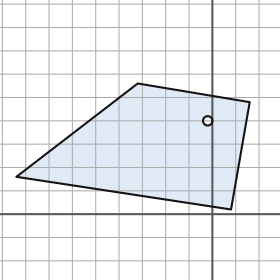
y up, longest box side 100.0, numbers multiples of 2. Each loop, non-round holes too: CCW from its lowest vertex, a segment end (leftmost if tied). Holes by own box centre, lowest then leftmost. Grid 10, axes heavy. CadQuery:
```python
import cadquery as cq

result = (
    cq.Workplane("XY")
    .moveTo(8.0, 2.0)
    .lineTo(16.0, 48.0)
    .lineTo(-32.0, 56.0)
    .lineTo(-84.0, 16.0)
    .close()
    .moveTo(-2.0, 40.0)
    .circle(2.0)
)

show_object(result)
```